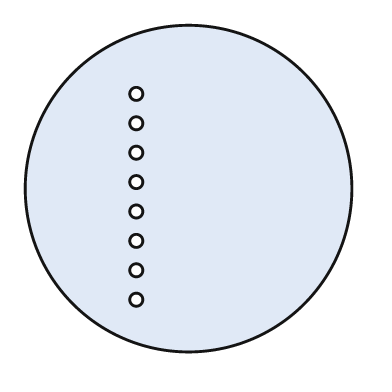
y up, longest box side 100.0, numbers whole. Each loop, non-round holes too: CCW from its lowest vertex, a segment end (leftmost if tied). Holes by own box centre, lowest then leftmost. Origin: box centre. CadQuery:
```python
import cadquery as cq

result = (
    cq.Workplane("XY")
    .moveTo(0.0, 0.0)
    .circle(50.0)
    .moveTo(-16.0, -34.0)
    .circle(2.0)
    .moveTo(-16.0, -25.0)
    .circle(2.0)
    .moveTo(-16.0, -16.0)
    .circle(2.0)
    .moveTo(-16.0, -7.0)
    .circle(2.0)
    .moveTo(-16.0, 2.0)
    .circle(2.0)
    .moveTo(-16.0, 11.0)
    .circle(2.0)
    .moveTo(-16.0, 20.0)
    .circle(2.0)
    .moveTo(-16.0, 29.0)
    .circle(2.0)
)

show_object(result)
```